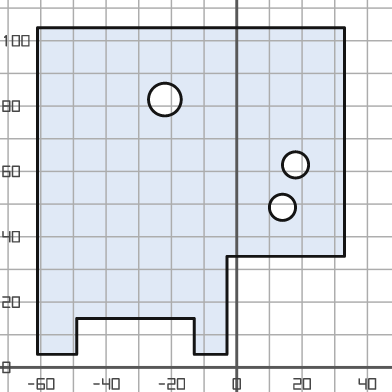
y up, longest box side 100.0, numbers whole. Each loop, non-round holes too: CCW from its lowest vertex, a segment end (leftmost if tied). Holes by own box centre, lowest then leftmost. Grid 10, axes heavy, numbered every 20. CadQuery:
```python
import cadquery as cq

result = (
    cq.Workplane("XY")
    .moveTo(-61.0, 4.0)
    .lineTo(-49.0, 4.0)
    .lineTo(-49.0, 15.0)
    .lineTo(-13.0, 15.0)
    .lineTo(-13.0, 4.0)
    .lineTo(-3.0, 4.0)
    .lineTo(-3.0, 34.0)
    .lineTo(33.0, 34.0)
    .lineTo(33.0, 104.0)
    .lineTo(-61.0, 104.0)
    .close()
    .moveTo(14.0, 49.0)
    .circle(4.0)
    .moveTo(18.0, 62.0)
    .circle(4.0)
    .moveTo(-22.0, 82.0)
    .circle(5.0)
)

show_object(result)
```